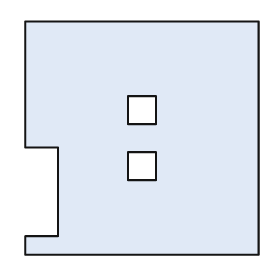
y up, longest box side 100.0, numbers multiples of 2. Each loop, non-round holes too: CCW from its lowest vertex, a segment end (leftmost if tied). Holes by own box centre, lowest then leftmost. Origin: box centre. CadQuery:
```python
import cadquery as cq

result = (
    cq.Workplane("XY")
    .moveTo(-50.0, -50.0)
    .lineTo(50.0, -50.0)
    .lineTo(50.0, 50.0)
    .lineTo(-50.0, 50.0)
    .lineTo(-50.0, -4.0)
    .lineTo(-36.0, -4.0)
    .lineTo(-36.0, -42.0)
    .lineTo(-50.0, -42.0)
    .close()
    .moveTo(-6.0, -18.0)
    .lineTo(6.0, -18.0)
    .lineTo(6.0, -6.0)
    .lineTo(-6.0, -6.0)
    .close()
    .moveTo(-6.0, 6.0)
    .lineTo(6.0, 6.0)
    .lineTo(6.0, 18.0)
    .lineTo(-6.0, 18.0)
    .close()
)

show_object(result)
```